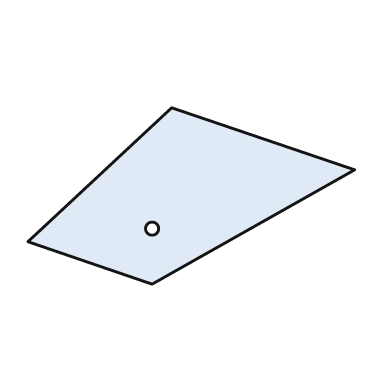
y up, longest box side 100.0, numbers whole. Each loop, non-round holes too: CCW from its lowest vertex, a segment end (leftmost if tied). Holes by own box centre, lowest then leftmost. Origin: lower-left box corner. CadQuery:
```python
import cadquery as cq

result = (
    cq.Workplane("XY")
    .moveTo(38.0, 0.0)
    .lineTo(100.0, 35.0)
    .lineTo(44.0, 54.0)
    .lineTo(0.0, 13.0)
    .close()
    .moveTo(38.0, 17.0)
    .circle(2.0)
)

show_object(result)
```